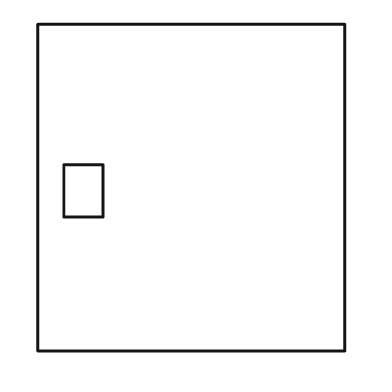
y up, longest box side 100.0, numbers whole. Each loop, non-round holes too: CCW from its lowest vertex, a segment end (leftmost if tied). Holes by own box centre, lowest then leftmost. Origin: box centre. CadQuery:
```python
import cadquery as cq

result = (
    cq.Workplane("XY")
    .moveTo(-47.0, -50.0)
    .lineTo(47.0, -50.0)
    .lineTo(47.0, 50.0)
    .lineTo(-47.0, 50.0)
    .close()
    .moveTo(-39.0, -9.0)
    .lineTo(-27.0, -9.0)
    .lineTo(-27.0, 7.0)
    .lineTo(-39.0, 7.0)
    .close()
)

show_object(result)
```